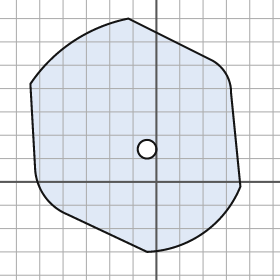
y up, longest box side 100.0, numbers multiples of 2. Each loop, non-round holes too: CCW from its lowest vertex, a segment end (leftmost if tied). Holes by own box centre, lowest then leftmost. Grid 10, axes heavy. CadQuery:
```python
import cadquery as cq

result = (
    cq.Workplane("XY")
    .moveTo(-4.0, -30.0)
    .threePointArc((20.0, -22.0), (36.0, -2.0))
    .lineTo(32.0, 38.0)
    .threePointArc((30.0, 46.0), (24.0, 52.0))
    .lineTo(-12.0, 70.0)
    .threePointArc((-36.0, 60.0), (-54.0, 42.0))
    .lineTo(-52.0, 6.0)
    .threePointArc((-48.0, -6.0), (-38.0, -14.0))
    .close()
    .moveTo(-4.0, 14.0)
    .circle(4.0)
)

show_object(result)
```